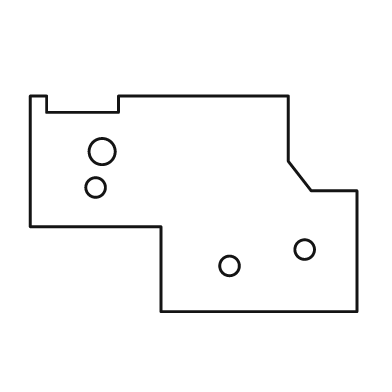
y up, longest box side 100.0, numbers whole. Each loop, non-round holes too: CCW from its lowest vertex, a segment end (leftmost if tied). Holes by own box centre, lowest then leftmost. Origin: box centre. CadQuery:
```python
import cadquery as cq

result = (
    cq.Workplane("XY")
    .moveTo(-10.0, -33.0)
    .lineTo(50.0, -33.0)
    .lineTo(50.0, 4.0)
    .lineTo(36.0, 4.0)
    .lineTo(29.0, 13.0)
    .lineTo(29.0, 33.0)
    .lineTo(-23.0, 33.0)
    .lineTo(-23.0, 28.0)
    .lineTo(-45.0, 28.0)
    .lineTo(-45.0, 33.0)
    .lineTo(-50.0, 33.0)
    .lineTo(-50.0, -7.0)
    .lineTo(-10.0, -7.0)
    .close()
    .moveTo(11.0, -19.0)
    .circle(3.0)
    .moveTo(34.0, -14.0)
    .circle(3.0)
    .moveTo(-30.0, 5.0)
    .circle(3.0)
    .moveTo(-28.0, 16.0)
    .circle(4.0)
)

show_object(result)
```